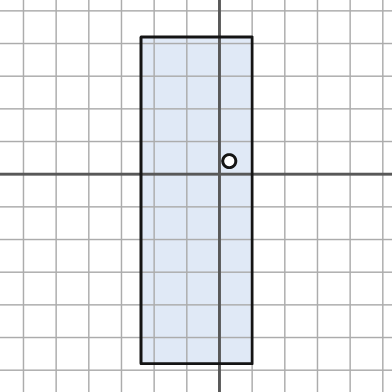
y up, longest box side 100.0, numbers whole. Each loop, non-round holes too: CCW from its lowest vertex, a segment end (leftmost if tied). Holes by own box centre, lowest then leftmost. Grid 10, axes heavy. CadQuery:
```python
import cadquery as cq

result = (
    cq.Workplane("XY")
    .moveTo(-24.0, -58.0)
    .lineTo(10.0, -58.0)
    .lineTo(10.0, 42.0)
    .lineTo(-24.0, 42.0)
    .close()
    .moveTo(3.0, 4.0)
    .circle(2.0)
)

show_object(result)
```